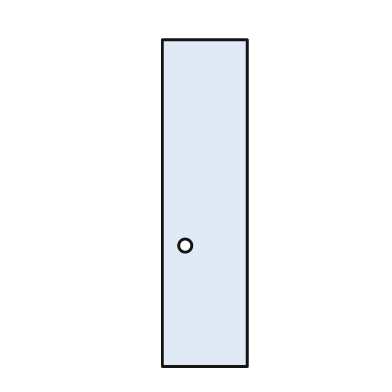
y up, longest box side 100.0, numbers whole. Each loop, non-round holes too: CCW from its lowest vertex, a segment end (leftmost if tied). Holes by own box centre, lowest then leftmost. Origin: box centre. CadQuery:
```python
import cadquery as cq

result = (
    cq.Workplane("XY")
    .moveTo(-13.0, -50.0)
    .lineTo(13.0, -50.0)
    .lineTo(13.0, 50.0)
    .lineTo(-13.0, 50.0)
    .close()
    .moveTo(-6.0, -13.0)
    .circle(2.0)
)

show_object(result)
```